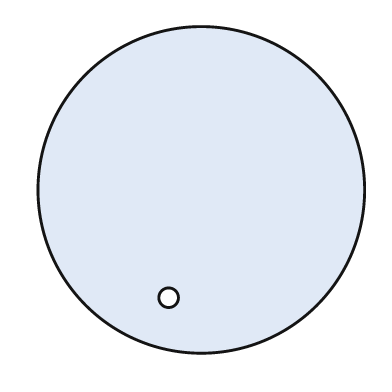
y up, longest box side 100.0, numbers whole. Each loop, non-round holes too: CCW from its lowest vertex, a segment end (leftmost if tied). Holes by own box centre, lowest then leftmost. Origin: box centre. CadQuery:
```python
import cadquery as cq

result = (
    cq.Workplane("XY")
    .moveTo(0.0, 0.0)
    .circle(50.0)
    .moveTo(-10.0, -33.0)
    .circle(3.0)
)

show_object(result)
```